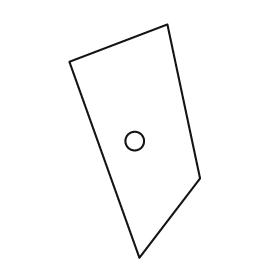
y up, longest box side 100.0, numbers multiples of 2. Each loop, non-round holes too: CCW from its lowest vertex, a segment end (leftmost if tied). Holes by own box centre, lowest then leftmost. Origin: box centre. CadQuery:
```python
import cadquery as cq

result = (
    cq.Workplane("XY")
    .moveTo(2.0, -50.0)
    .lineTo(28.0, -16.0)
    .lineTo(14.0, 50.0)
    .lineTo(-28.0, 34.0)
    .close()
    .moveTo(0.0, 0.0)
    .circle(4.0)
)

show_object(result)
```